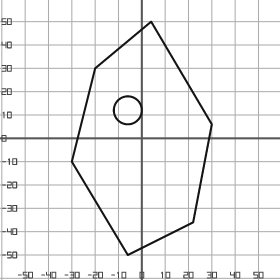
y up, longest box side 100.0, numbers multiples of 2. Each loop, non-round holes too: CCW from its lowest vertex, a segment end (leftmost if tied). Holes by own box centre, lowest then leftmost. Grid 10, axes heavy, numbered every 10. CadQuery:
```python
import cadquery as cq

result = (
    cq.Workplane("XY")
    .moveTo(-6.0, -50.0)
    .lineTo(22.0, -36.0)
    .lineTo(30.0, 6.0)
    .lineTo(4.0, 50.0)
    .lineTo(-20.0, 30.0)
    .lineTo(-30.0, -10.0)
    .close()
    .moveTo(-6.0, 12.0)
    .circle(6.0)
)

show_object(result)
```